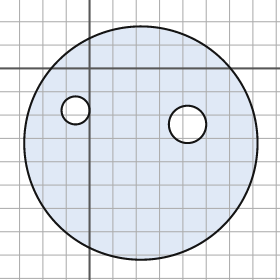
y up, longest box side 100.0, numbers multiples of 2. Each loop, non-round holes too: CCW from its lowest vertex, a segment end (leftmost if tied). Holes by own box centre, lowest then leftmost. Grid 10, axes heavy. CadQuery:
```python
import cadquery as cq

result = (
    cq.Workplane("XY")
    .moveTo(22.0, -32.0)
    .circle(50.0)
    .moveTo(42.0, -24.0)
    .circle(8.0)
    .moveTo(-6.0, -18.0)
    .circle(6.0)
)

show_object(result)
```